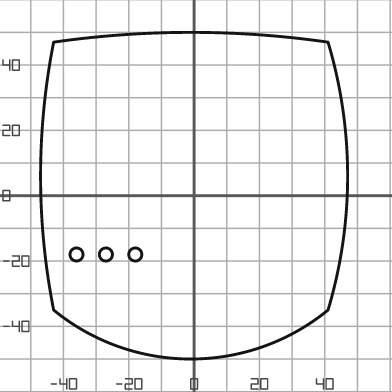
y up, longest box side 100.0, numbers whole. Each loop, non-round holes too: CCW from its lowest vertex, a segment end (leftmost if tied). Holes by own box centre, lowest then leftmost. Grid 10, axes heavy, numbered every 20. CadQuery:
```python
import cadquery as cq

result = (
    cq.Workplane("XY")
    .moveTo(-43.0, -35.0)
    .threePointArc((-1.0, -50.0), (41.0, -35.0))
    .threePointArc((47.0, 6.0), (41.0, 47.0))
    .threePointArc((-1.0, 50.0), (-43.0, 47.0))
    .threePointArc((-47.0, 6.0), (-43.0, -35.0))
    .close()
    .moveTo(-36.0, -18.0)
    .circle(2.0)
    .moveTo(-27.0, -18.0)
    .circle(2.0)
    .moveTo(-18.0, -18.0)
    .circle(2.0)
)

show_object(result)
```